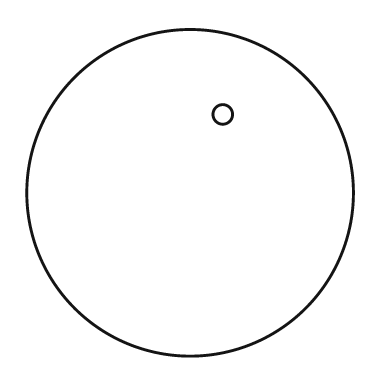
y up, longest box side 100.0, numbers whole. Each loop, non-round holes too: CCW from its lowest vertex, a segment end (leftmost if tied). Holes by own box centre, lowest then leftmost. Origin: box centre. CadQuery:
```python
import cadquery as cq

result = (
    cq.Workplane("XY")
    .moveTo(0.0, 0.0)
    .circle(50.0)
    .moveTo(10.0, 24.0)
    .circle(3.0)
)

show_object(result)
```